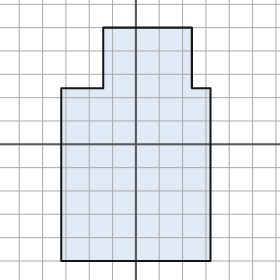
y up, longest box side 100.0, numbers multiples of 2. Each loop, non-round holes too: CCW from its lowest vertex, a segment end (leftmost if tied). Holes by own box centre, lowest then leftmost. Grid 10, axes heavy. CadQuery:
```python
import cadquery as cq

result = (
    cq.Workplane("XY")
    .moveTo(-32.0, -50.0)
    .lineTo(32.0, -50.0)
    .lineTo(32.0, 24.0)
    .lineTo(24.0, 24.0)
    .lineTo(24.0, 50.0)
    .lineTo(-14.0, 50.0)
    .lineTo(-14.0, 24.0)
    .lineTo(-32.0, 24.0)
    .close()
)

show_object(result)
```